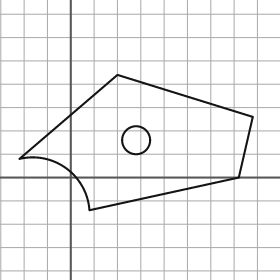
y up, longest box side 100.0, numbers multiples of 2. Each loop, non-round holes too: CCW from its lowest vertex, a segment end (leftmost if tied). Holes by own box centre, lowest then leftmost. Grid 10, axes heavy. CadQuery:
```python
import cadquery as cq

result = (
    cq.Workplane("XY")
    .moveTo(8.0, -14.0)
    .lineTo(72.0, 0.0)
    .lineTo(78.0, 26.0)
    .lineTo(20.0, 44.0)
    .lineTo(-22.0, 8.0)
    .threePointArc((-2.0, 4.0), (8.0, -14.0))
    .close()
    .moveTo(28.0, 16.0)
    .circle(6.0)
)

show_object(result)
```